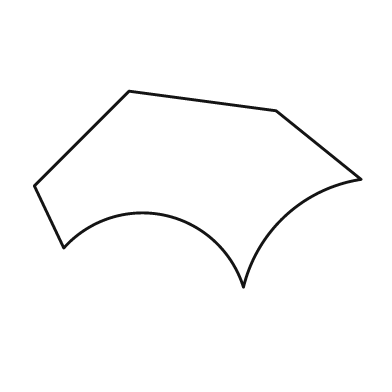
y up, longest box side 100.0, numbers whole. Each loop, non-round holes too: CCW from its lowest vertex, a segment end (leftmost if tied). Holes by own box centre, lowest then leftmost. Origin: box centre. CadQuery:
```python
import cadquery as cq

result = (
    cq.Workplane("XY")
    .moveTo(14.0, -30.0)
    .threePointArc((27.0, -8.0), (50.0, 3.0))
    .lineTo(24.0, 24.0)
    .lineTo(-21.0, 30.0)
    .lineTo(-50.0, 1.0)
    .lineTo(-41.0, -18.0)
    .threePointArc((-10.0, -8.0), (14.0, -30.0))
    .close()
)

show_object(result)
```